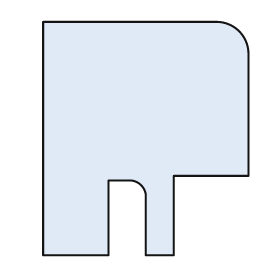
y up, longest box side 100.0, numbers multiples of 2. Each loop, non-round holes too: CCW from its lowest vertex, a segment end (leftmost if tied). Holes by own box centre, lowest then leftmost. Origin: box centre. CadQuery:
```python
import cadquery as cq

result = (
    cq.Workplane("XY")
    .moveTo(-44.0, -50.0)
    .lineTo(-16.0, -50.0)
    .lineTo(-16.0, -18.0)
    .lineTo(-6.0, -18.0)
    .threePointArc((-2.0, -20.0), (0.0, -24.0))
    .lineTo(0.0, -50.0)
    .lineTo(12.0, -50.0)
    .lineTo(12.0, -16.0)
    .lineTo(44.0, -16.0)
    .lineTo(44.0, 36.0)
    .threePointArc((40.0, 46.0), (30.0, 50.0))
    .lineTo(-44.0, 50.0)
    .close()
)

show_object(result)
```